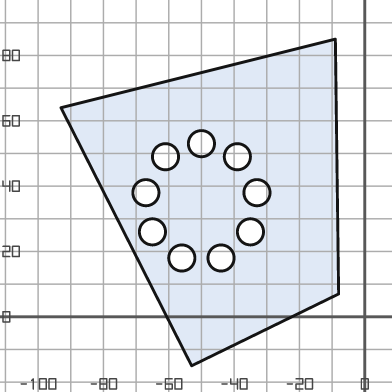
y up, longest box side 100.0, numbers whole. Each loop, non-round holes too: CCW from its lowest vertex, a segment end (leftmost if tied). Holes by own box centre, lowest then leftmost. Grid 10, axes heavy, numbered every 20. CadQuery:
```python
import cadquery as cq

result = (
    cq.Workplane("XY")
    .moveTo(-53.0, -15.0)
    .lineTo(-8.0, 7.0)
    .lineTo(-9.0, 85.0)
    .lineTo(-93.0, 64.0)
    .close()
    .moveTo(-56.0, 18.0)
    .circle(4.0)
    .moveTo(-44.0, 18.0)
    .circle(4.0)
    .moveTo(-65.0, 26.0)
    .circle(4.0)
    .moveTo(-35.0, 26.0)
    .circle(4.0)
    .moveTo(-67.0, 38.0)
    .circle(4.0)
    .moveTo(-33.0, 38.0)
    .circle(4.0)
    .moveTo(-61.0, 49.0)
    .circle(4.0)
    .moveTo(-39.0, 49.0)
    .circle(4.0)
    .moveTo(-50.0, 53.0)
    .circle(4.0)
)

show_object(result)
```